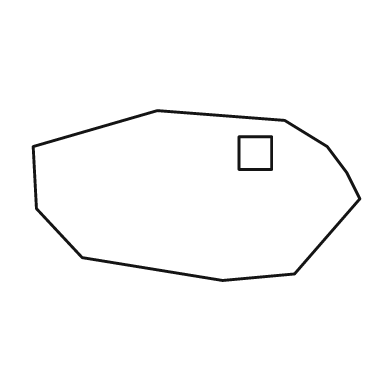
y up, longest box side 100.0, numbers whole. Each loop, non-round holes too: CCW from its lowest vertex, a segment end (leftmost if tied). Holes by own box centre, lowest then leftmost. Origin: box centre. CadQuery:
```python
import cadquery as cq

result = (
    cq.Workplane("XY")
    .moveTo(8.0, -26.0)
    .lineTo(30.0, -24.0)
    .lineTo(50.0, -1.0)
    .lineTo(46.0, 7.0)
    .lineTo(40.0, 15.0)
    .lineTo(27.0, 23.0)
    .lineTo(-12.0, 26.0)
    .lineTo(-50.0, 15.0)
    .lineTo(-49.0, -4.0)
    .lineTo(-35.0, -19.0)
    .close()
    .moveTo(13.0, 8.0)
    .lineTo(23.0, 8.0)
    .lineTo(23.0, 18.0)
    .lineTo(13.0, 18.0)
    .close()
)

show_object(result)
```